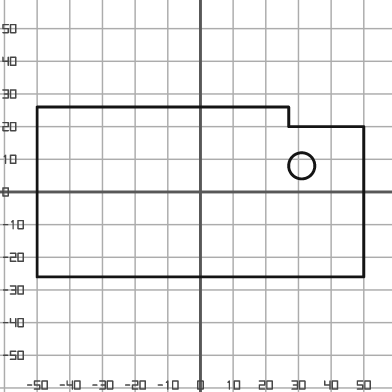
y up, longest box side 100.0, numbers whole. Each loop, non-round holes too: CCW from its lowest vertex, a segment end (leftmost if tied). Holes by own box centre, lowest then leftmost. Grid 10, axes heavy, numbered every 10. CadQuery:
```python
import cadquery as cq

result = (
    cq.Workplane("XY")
    .moveTo(-50.0, -26.0)
    .lineTo(50.0, -26.0)
    .lineTo(50.0, 20.0)
    .lineTo(27.0, 20.0)
    .lineTo(27.0, 26.0)
    .lineTo(-50.0, 26.0)
    .close()
    .moveTo(31.0, 8.0)
    .circle(4.0)
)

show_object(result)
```